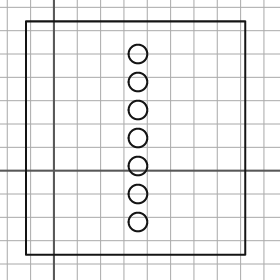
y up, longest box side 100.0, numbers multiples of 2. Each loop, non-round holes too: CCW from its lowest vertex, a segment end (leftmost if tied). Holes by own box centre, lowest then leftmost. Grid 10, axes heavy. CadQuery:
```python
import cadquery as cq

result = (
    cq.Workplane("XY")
    .moveTo(-12.0, -36.0)
    .lineTo(82.0, -36.0)
    .lineTo(82.0, 64.0)
    .lineTo(-12.0, 64.0)
    .close()
    .moveTo(36.0, -22.0)
    .circle(4.0)
    .moveTo(36.0, -10.0)
    .circle(4.0)
    .moveTo(36.0, 2.0)
    .circle(4.0)
    .moveTo(36.0, 14.0)
    .circle(4.0)
    .moveTo(36.0, 26.0)
    .circle(4.0)
    .moveTo(36.0, 38.0)
    .circle(4.0)
    .moveTo(36.0, 50.0)
    .circle(4.0)
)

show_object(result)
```